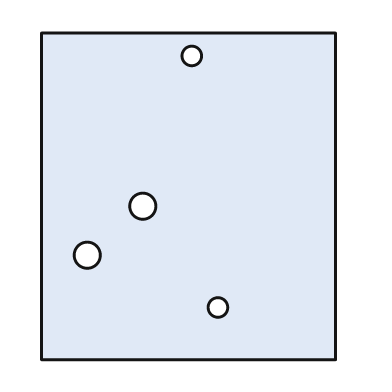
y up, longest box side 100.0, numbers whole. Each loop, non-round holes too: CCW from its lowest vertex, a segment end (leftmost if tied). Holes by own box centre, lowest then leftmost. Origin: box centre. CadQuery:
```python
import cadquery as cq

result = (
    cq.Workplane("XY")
    .moveTo(-45.0, -50.0)
    .lineTo(45.0, -50.0)
    .lineTo(45.0, 50.0)
    .lineTo(-45.0, 50.0)
    .close()
    .moveTo(9.0, -34.0)
    .circle(3.0)
    .moveTo(-31.0, -18.0)
    .circle(4.0)
    .moveTo(-14.0, -3.0)
    .circle(4.0)
    .moveTo(1.0, 43.0)
    .circle(3.0)
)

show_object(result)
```